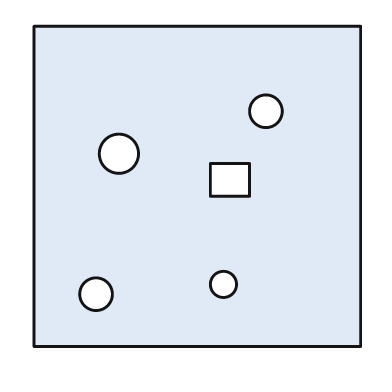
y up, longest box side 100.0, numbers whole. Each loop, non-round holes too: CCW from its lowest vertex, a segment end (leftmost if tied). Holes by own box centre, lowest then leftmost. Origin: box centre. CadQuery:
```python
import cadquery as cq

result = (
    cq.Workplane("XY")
    .moveTo(-50.0, -49.0)
    .lineTo(50.0, -49.0)
    .lineTo(50.0, 49.0)
    .lineTo(-50.0, 49.0)
    .close()
    .moveTo(-31.0, -33.0)
    .circle(5.0)
    .moveTo(8.0, -30.0)
    .circle(4.0)
    .moveTo(4.0, -3.0)
    .lineTo(16.0, -3.0)
    .lineTo(16.0, 7.0)
    .lineTo(4.0, 7.0)
    .close()
    .moveTo(-24.0, 10.0)
    .circle(6.0)
    .moveTo(21.0, 23.0)
    .circle(5.0)
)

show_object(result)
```